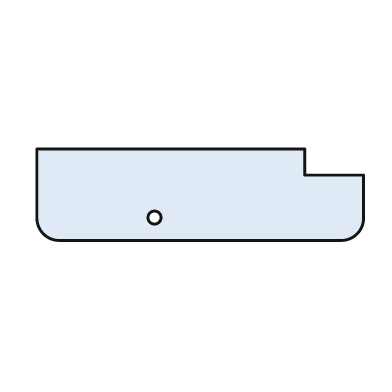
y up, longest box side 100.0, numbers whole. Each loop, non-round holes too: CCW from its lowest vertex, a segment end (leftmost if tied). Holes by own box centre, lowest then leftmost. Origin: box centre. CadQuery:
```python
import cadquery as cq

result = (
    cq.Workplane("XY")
    .moveTo(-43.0, -14.0)
    .lineTo(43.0, -14.0)
    .threePointArc((48.0, -12.0), (50.0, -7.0))
    .lineTo(50.0, 6.0)
    .lineTo(32.0, 6.0)
    .lineTo(32.0, 14.0)
    .lineTo(-50.0, 14.0)
    .lineTo(-50.0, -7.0)
    .threePointArc((-48.0, -12.0), (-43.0, -14.0))
    .close()
    .moveTo(-14.0, -7.0)
    .circle(2.0)
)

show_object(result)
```